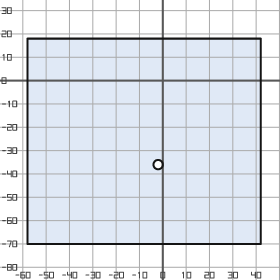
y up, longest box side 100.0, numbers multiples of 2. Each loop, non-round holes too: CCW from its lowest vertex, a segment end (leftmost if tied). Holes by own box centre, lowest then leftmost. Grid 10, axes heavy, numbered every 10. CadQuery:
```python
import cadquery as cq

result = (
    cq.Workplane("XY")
    .moveTo(-58.0, -70.0)
    .lineTo(42.0, -70.0)
    .lineTo(42.0, 18.0)
    .lineTo(-58.0, 18.0)
    .close()
    .moveTo(-2.0, -36.0)
    .circle(2.0)
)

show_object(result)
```